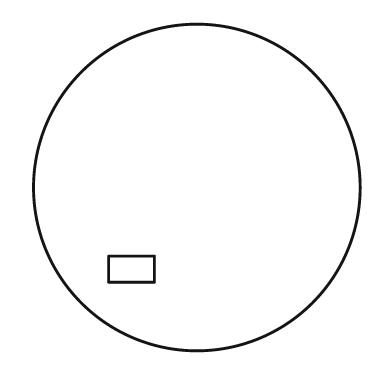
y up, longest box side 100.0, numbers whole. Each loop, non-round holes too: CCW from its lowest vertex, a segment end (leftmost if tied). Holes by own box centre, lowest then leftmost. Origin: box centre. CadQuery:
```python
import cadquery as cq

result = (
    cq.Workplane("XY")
    .moveTo(0.0, 0.0)
    .circle(50.0)
    .moveTo(-27.0, -29.0)
    .lineTo(-13.0, -29.0)
    .lineTo(-13.0, -21.0)
    .lineTo(-27.0, -21.0)
    .close()
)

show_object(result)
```